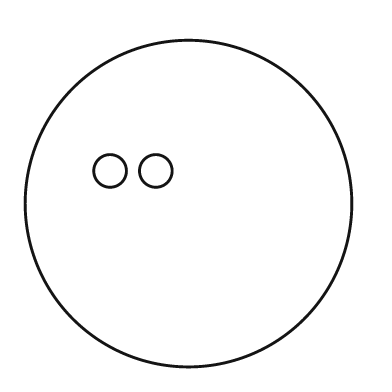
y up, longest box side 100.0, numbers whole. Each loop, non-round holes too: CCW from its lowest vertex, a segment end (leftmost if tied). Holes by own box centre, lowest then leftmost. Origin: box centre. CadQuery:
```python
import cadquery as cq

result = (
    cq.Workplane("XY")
    .moveTo(0.0, 0.0)
    .circle(50.0)
    .moveTo(-24.0, 10.0)
    .circle(5.0)
    .moveTo(-10.0, 10.0)
    .circle(5.0)
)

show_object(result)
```